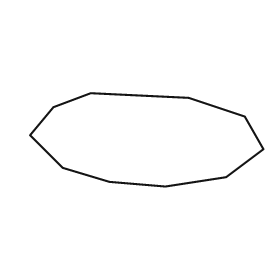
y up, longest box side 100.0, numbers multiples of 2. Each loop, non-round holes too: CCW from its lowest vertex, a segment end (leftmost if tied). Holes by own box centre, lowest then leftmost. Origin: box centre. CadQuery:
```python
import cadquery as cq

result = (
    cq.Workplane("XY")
    .moveTo(8.0, -20.0)
    .lineTo(34.0, -16.0)
    .lineTo(50.0, -4.0)
    .lineTo(42.0, 10.0)
    .lineTo(18.0, 18.0)
    .lineTo(-24.0, 20.0)
    .lineTo(-40.0, 14.0)
    .lineTo(-50.0, 2.0)
    .lineTo(-36.0, -12.0)
    .lineTo(-16.0, -18.0)
    .close()
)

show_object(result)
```